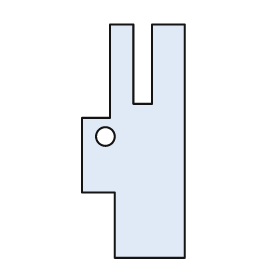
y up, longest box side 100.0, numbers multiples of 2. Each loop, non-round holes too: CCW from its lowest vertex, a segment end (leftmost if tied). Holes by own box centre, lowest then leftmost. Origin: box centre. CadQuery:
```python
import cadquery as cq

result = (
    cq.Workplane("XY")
    .moveTo(-8.0, -50.0)
    .lineTo(22.0, -50.0)
    .lineTo(22.0, 50.0)
    .lineTo(8.0, 50.0)
    .lineTo(8.0, 16.0)
    .lineTo(0.0, 16.0)
    .lineTo(0.0, 50.0)
    .lineTo(-10.0, 50.0)
    .lineTo(-10.0, 10.0)
    .lineTo(-22.0, 10.0)
    .lineTo(-22.0, -22.0)
    .lineTo(-8.0, -22.0)
    .close()
    .moveTo(-12.0, 2.0)
    .circle(4.0)
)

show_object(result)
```